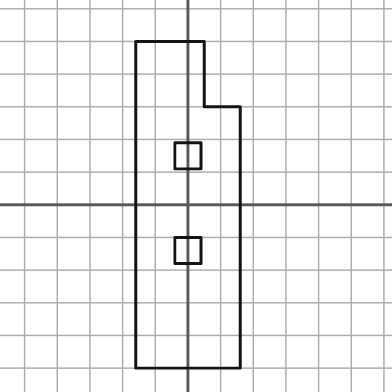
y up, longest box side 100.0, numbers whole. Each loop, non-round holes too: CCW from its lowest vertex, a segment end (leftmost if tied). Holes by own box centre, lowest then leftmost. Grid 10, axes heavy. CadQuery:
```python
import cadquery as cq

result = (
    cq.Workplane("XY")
    .moveTo(-16.0, -50.0)
    .lineTo(16.0, -50.0)
    .lineTo(16.0, 30.0)
    .lineTo(5.0, 30.0)
    .lineTo(5.0, 50.0)
    .lineTo(-16.0, 50.0)
    .close()
    .moveTo(-4.0, -18.0)
    .lineTo(4.0, -18.0)
    .lineTo(4.0, -10.0)
    .lineTo(-4.0, -10.0)
    .close()
    .moveTo(-4.0, 11.0)
    .lineTo(4.0, 11.0)
    .lineTo(4.0, 19.0)
    .lineTo(-4.0, 19.0)
    .close()
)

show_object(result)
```